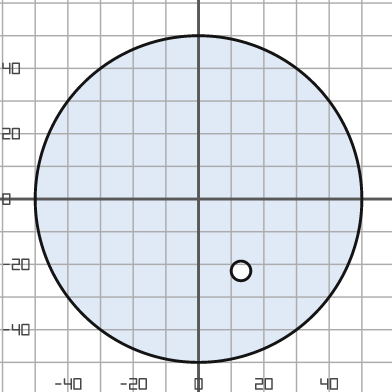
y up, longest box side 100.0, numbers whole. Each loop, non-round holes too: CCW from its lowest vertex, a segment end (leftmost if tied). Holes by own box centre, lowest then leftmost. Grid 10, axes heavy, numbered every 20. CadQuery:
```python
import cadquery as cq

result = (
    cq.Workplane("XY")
    .moveTo(0.0, 0.0)
    .circle(50.0)
    .moveTo(13.0, -22.0)
    .circle(3.0)
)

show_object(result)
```